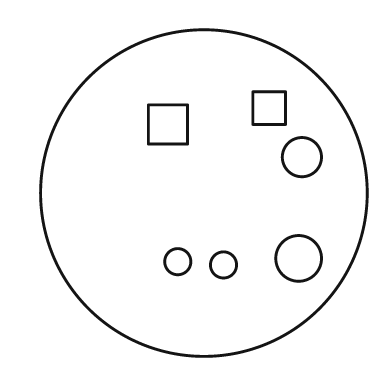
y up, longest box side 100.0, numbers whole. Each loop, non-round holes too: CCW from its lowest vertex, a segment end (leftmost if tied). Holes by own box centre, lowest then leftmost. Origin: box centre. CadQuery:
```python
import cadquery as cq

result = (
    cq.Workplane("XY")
    .moveTo(0.0, 0.0)
    .circle(50.0)
    .moveTo(6.0, -22.0)
    .circle(4.0)
    .moveTo(-8.0, -21.0)
    .circle(4.0)
    .moveTo(29.0, -20.0)
    .circle(7.0)
    .moveTo(30.0, 11.0)
    .circle(6.0)
    .moveTo(-17.0, 15.0)
    .lineTo(-5.0, 15.0)
    .lineTo(-5.0, 27.0)
    .lineTo(-17.0, 27.0)
    .close()
    .moveTo(15.0, 21.0)
    .lineTo(25.0, 21.0)
    .lineTo(25.0, 31.0)
    .lineTo(15.0, 31.0)
    .close()
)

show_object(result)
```